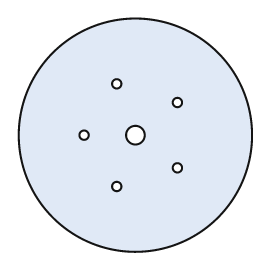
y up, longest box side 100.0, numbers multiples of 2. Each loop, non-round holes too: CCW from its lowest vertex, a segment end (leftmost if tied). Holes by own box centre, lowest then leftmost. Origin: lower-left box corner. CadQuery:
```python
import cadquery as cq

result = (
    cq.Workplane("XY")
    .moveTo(50.0, 50.0)
    .circle(50.0)
    .moveTo(42.0, 28.0)
    .circle(2.0)
    .moveTo(68.0, 36.0)
    .circle(2.0)
    .moveTo(28.0, 50.0)
    .circle(2.0)
    .moveTo(50.0, 50.0)
    .circle(4.0)
    .moveTo(68.0, 64.0)
    .circle(2.0)
    .moveTo(42.0, 72.0)
    .circle(2.0)
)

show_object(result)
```